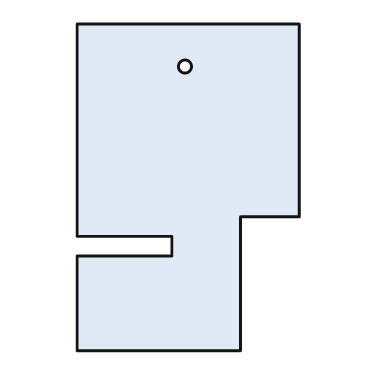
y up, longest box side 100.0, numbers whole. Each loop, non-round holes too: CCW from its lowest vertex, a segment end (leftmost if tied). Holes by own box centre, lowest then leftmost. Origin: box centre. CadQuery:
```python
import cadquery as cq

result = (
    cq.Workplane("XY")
    .moveTo(-34.0, -50.0)
    .lineTo(16.0, -50.0)
    .lineTo(16.0, -9.0)
    .lineTo(34.0, -9.0)
    .lineTo(34.0, 50.0)
    .lineTo(-34.0, 50.0)
    .lineTo(-34.0, -15.0)
    .lineTo(-5.0, -15.0)
    .lineTo(-5.0, -21.0)
    .lineTo(-34.0, -21.0)
    .close()
    .moveTo(-1.0, 37.0)
    .circle(2.0)
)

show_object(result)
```